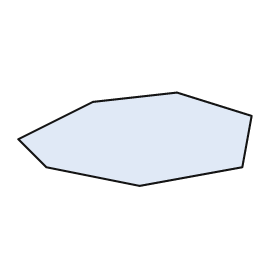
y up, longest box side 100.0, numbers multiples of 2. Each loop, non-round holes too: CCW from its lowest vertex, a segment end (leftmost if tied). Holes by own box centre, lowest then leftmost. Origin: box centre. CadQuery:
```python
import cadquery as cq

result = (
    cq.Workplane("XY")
    .moveTo(2.0, -20.0)
    .lineTo(46.0, -12.0)
    .lineTo(50.0, 10.0)
    .lineTo(18.0, 20.0)
    .lineTo(-18.0, 16.0)
    .lineTo(-50.0, 0.0)
    .lineTo(-38.0, -12.0)
    .close()
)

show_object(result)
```